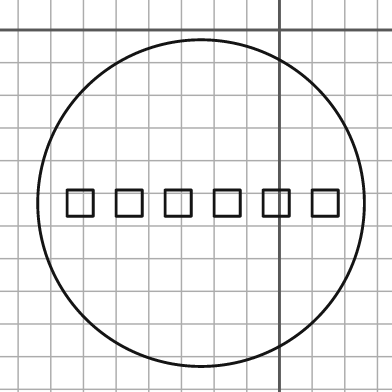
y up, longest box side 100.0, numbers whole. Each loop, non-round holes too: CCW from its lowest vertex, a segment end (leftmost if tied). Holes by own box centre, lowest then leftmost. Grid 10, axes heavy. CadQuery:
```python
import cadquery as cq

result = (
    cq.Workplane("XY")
    .moveTo(-24.0, -53.0)
    .circle(50.0)
    .moveTo(-65.0, -57.0)
    .lineTo(-57.0, -57.0)
    .lineTo(-57.0, -49.0)
    .lineTo(-65.0, -49.0)
    .close()
    .moveTo(-50.0, -57.0)
    .lineTo(-42.0, -57.0)
    .lineTo(-42.0, -49.0)
    .lineTo(-50.0, -49.0)
    .close()
    .moveTo(-35.0, -57.0)
    .lineTo(-27.0, -57.0)
    .lineTo(-27.0, -49.0)
    .lineTo(-35.0, -49.0)
    .close()
    .moveTo(-20.0, -57.0)
    .lineTo(-12.0, -57.0)
    .lineTo(-12.0, -49.0)
    .lineTo(-20.0, -49.0)
    .close()
    .moveTo(-5.0, -57.0)
    .lineTo(3.0, -57.0)
    .lineTo(3.0, -49.0)
    .lineTo(-5.0, -49.0)
    .close()
    .moveTo(10.0, -57.0)
    .lineTo(18.0, -57.0)
    .lineTo(18.0, -49.0)
    .lineTo(10.0, -49.0)
    .close()
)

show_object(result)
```